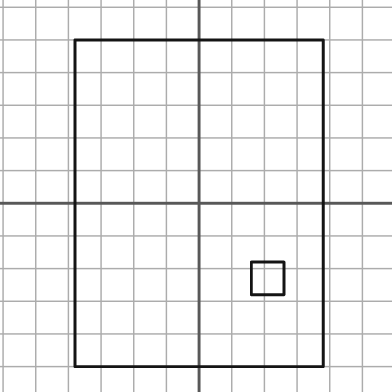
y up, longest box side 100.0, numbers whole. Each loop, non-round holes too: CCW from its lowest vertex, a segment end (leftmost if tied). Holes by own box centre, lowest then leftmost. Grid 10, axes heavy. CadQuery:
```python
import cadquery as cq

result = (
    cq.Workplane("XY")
    .moveTo(-38.0, -50.0)
    .lineTo(38.0, -50.0)
    .lineTo(38.0, 50.0)
    .lineTo(-38.0, 50.0)
    .close()
    .moveTo(16.0, -28.0)
    .lineTo(26.0, -28.0)
    .lineTo(26.0, -18.0)
    .lineTo(16.0, -18.0)
    .close()
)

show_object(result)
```